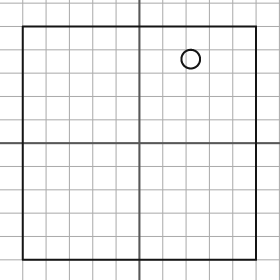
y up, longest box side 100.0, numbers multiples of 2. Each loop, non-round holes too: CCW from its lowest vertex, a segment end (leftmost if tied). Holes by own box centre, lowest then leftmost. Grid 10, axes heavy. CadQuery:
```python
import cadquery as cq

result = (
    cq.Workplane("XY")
    .moveTo(-50.0, -50.0)
    .lineTo(50.0, -50.0)
    .lineTo(50.0, 50.0)
    .lineTo(-50.0, 50.0)
    .close()
    .moveTo(22.0, 36.0)
    .circle(4.0)
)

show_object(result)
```